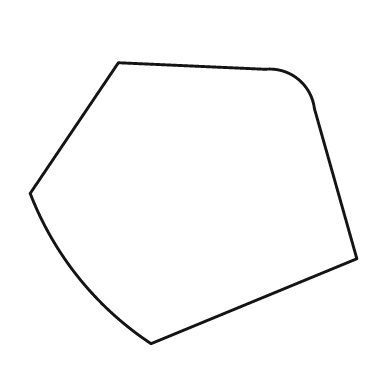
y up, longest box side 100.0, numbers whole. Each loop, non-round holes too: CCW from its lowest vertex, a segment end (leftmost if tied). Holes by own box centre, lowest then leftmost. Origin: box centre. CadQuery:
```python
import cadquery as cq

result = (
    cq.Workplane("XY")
    .moveTo(-13.0, -43.0)
    .lineTo(50.0, -17.0)
    .lineTo(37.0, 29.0)
    .threePointArc((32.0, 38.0), (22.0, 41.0))
    .lineTo(-23.0, 43.0)
    .lineTo(-50.0, 3.0)
    .threePointArc((-35.0, -23.0), (-13.0, -43.0))
    .close()
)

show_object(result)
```